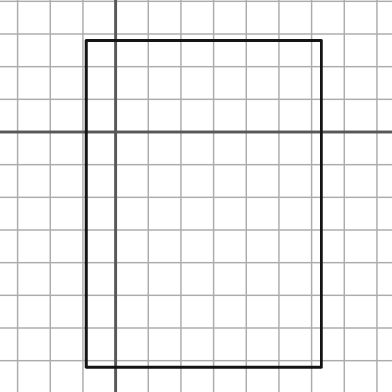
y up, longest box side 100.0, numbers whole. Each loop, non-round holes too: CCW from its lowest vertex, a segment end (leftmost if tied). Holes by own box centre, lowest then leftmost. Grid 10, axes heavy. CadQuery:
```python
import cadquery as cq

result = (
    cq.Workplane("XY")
    .moveTo(-9.0, -72.0)
    .lineTo(63.0, -72.0)
    .lineTo(63.0, 28.0)
    .lineTo(-9.0, 28.0)
    .close()
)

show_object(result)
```